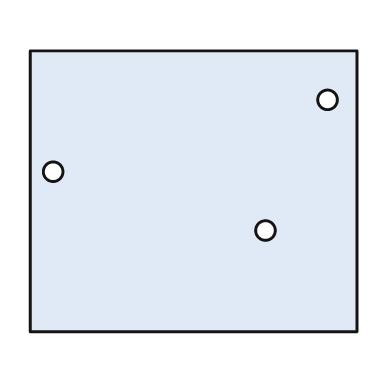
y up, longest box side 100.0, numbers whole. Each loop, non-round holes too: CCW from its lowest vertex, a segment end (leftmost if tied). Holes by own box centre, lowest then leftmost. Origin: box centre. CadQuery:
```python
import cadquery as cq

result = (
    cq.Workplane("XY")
    .moveTo(-50.0, -43.0)
    .lineTo(50.0, -43.0)
    .lineTo(50.0, 43.0)
    .lineTo(-50.0, 43.0)
    .close()
    .moveTo(22.0, -12.0)
    .circle(3.0)
    .moveTo(-43.0, 6.0)
    .circle(3.0)
    .moveTo(41.0, 28.0)
    .circle(3.0)
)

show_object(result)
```